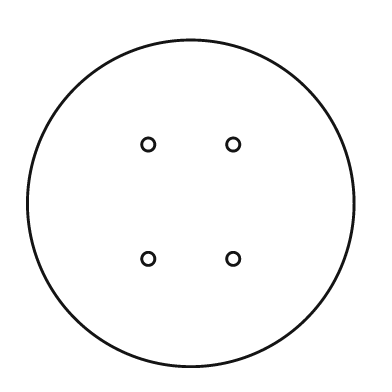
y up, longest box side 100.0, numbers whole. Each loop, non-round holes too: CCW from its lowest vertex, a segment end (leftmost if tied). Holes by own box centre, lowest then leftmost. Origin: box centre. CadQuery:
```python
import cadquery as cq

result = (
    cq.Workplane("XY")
    .moveTo(0.0, 0.0)
    .circle(50.0)
    .moveTo(-13.0, -17.0)
    .circle(2.0)
    .moveTo(13.0, -17.0)
    .circle(2.0)
    .moveTo(-13.0, 18.0)
    .circle(2.0)
    .moveTo(13.0, 18.0)
    .circle(2.0)
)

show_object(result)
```